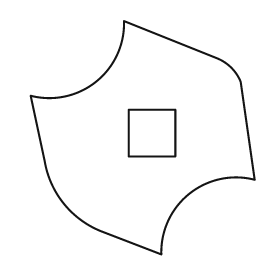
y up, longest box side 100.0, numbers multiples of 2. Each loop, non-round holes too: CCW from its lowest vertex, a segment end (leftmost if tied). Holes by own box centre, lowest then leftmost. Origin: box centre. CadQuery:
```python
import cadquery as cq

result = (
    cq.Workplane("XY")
    .moveTo(8.0, -50.0)
    .threePointArc((20.0, -24.0), (48.0, -18.0))
    .lineTo(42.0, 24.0)
    .threePointArc((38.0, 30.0), (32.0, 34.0))
    .lineTo(-8.0, 50.0)
    .threePointArc((-20.0, 24.0), (-48.0, 18.0))
    .lineTo(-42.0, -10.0)
    .threePointArc((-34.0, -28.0), (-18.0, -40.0))
    .close()
    .moveTo(-6.0, -8.0)
    .lineTo(14.0, -8.0)
    .lineTo(14.0, 12.0)
    .lineTo(-6.0, 12.0)
    .close()
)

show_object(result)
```